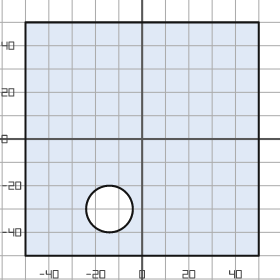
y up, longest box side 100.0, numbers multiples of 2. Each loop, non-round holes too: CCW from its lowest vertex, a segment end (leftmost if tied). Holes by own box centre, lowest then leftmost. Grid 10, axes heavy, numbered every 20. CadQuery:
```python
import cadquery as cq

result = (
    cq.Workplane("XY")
    .moveTo(-50.0, -50.0)
    .lineTo(50.0, -50.0)
    .lineTo(50.0, 50.0)
    .lineTo(-50.0, 50.0)
    .close()
    .moveTo(-14.0, -30.0)
    .circle(10.0)
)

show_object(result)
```